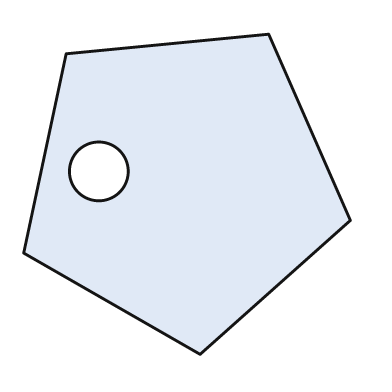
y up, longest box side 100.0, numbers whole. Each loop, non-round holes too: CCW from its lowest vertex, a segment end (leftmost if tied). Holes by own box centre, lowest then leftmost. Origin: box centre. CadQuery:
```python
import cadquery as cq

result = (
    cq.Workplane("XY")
    .moveTo(4.0, -49.0)
    .lineTo(50.0, -8.0)
    .lineTo(25.0, 49.0)
    .lineTo(-37.0, 43.0)
    .lineTo(-50.0, -18.0)
    .close()
    .moveTo(-27.0, 7.0)
    .circle(9.0)
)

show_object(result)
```